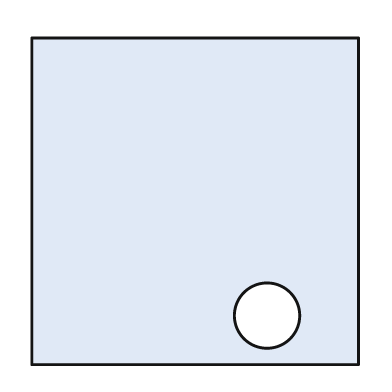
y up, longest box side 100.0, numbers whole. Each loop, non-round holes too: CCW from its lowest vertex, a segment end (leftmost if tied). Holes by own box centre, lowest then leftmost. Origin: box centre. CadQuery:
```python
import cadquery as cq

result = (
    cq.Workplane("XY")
    .moveTo(-50.0, -50.0)
    .lineTo(50.0, -50.0)
    .lineTo(50.0, 50.0)
    .lineTo(-50.0, 50.0)
    .close()
    .moveTo(22.0, -35.0)
    .circle(10.0)
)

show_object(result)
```